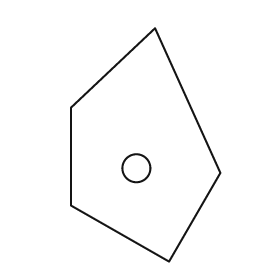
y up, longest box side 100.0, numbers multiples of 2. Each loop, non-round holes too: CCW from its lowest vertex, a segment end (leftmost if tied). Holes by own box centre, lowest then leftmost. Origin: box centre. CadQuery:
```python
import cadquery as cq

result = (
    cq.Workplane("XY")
    .moveTo(10.0, -50.0)
    .lineTo(32.0, -12.0)
    .lineTo(4.0, 50.0)
    .lineTo(-32.0, 16.0)
    .lineTo(-32.0, -26.0)
    .close()
    .moveTo(-4.0, -10.0)
    .circle(6.0)
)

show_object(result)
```